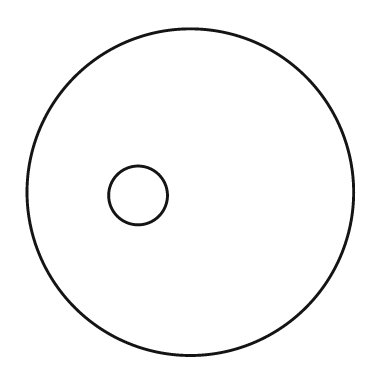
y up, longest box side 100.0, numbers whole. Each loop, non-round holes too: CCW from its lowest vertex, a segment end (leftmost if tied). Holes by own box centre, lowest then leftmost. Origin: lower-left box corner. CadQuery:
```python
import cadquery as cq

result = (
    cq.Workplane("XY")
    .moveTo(50.0, 50.0)
    .circle(50.0)
    .moveTo(34.0, 49.0)
    .circle(9.0)
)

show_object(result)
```